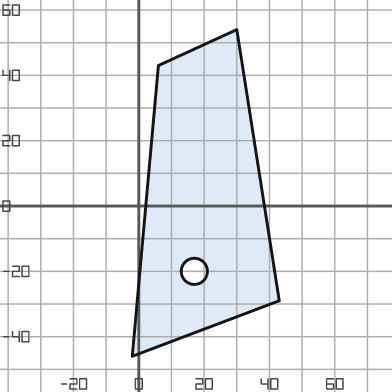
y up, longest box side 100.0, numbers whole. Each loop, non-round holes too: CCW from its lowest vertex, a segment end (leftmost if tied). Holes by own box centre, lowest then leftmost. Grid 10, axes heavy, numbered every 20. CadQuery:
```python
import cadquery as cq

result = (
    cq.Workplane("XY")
    .moveTo(-2.0, -46.0)
    .lineTo(43.0, -29.0)
    .lineTo(30.0, 54.0)
    .lineTo(6.0, 43.0)
    .close()
    .moveTo(17.0, -20.0)
    .circle(4.0)
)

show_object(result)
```